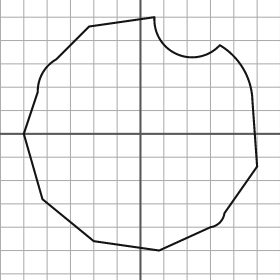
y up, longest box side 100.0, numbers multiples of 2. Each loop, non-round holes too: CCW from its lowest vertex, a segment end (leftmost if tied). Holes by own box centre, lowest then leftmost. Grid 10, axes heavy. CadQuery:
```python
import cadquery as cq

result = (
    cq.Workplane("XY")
    .moveTo(8.0, -50.0)
    .lineTo(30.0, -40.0)
    .threePointArc((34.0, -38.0), (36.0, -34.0))
    .lineTo(50.0, -14.0)
    .lineTo(48.0, 14.0)
    .threePointArc((44.0, 28.0), (34.0, 38.0))
    .threePointArc((16.0, 34.0), (6.0, 50.0))
    .lineTo(-22.0, 46.0)
    .lineTo(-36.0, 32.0)
    .threePointArc((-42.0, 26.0), (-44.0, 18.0))
    .lineTo(-50.0, 0.0)
    .lineTo(-42.0, -28.0)
    .lineTo(-20.0, -46.0)
    .close()
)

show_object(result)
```